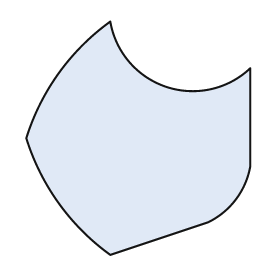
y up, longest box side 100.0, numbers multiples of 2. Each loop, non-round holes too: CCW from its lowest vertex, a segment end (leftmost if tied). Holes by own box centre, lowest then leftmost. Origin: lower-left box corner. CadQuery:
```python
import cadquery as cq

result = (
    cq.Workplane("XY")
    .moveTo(36.0, 0.0)
    .lineTo(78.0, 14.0)
    .threePointArc((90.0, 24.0), (96.0, 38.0))
    .lineTo(96.0, 80.0)
    .threePointArc((60.0, 72.0), (36.0, 100.0))
    .threePointArc((14.0, 78.0), (0.0, 50.0))
    .threePointArc((14.0, 22.0), (36.0, 0.0))
    .close()
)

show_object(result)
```